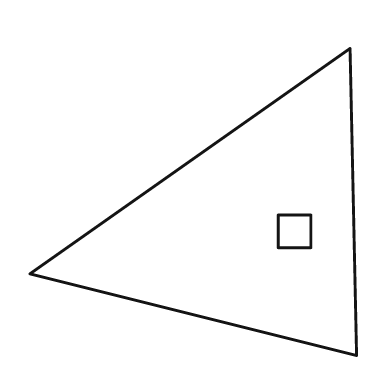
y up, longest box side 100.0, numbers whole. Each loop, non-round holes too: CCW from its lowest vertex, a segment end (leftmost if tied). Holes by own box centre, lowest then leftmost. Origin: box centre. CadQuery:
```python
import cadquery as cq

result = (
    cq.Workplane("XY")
    .moveTo(50.0, -47.0)
    .lineTo(48.0, 47.0)
    .lineTo(-50.0, -22.0)
    .close()
    .moveTo(26.0, -14.0)
    .lineTo(36.0, -14.0)
    .lineTo(36.0, -4.0)
    .lineTo(26.0, -4.0)
    .close()
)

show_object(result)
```